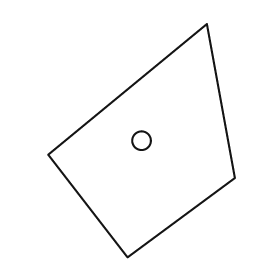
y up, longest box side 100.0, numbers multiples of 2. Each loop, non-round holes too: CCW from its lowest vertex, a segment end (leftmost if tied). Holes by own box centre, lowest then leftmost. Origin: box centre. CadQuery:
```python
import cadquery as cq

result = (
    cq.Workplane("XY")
    .moveTo(-6.0, -50.0)
    .lineTo(40.0, -16.0)
    .lineTo(28.0, 50.0)
    .lineTo(-40.0, -6.0)
    .close()
    .moveTo(0.0, 0.0)
    .circle(4.0)
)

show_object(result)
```